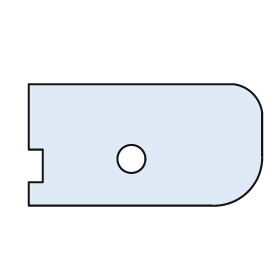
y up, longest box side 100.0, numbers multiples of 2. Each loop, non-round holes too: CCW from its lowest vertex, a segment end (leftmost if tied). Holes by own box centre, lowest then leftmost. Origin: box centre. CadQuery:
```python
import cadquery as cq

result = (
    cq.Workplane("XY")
    .moveTo(-50.0, -26.0)
    .lineTo(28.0, -26.0)
    .threePointArc((44.0, -20.0), (50.0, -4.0))
    .lineTo(50.0, 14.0)
    .threePointArc((46.0, 22.0), (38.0, 26.0))
    .lineTo(-50.0, 26.0)
    .lineTo(-50.0, -2.0)
    .lineTo(-44.0, -2.0)
    .lineTo(-44.0, -16.0)
    .lineTo(-50.0, -16.0)
    .close()
    .moveTo(-6.0, -6.0)
    .circle(6.0)
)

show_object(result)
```